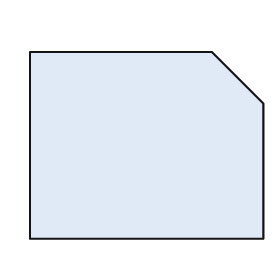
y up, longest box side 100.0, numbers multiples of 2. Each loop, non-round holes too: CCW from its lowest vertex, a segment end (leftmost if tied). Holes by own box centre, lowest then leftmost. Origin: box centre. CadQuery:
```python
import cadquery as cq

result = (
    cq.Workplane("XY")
    .moveTo(-50.0, -40.0)
    .lineTo(50.0, -40.0)
    .lineTo(50.0, 18.0)
    .lineTo(28.0, 40.0)
    .lineTo(-50.0, 40.0)
    .close()
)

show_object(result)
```